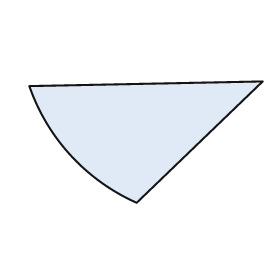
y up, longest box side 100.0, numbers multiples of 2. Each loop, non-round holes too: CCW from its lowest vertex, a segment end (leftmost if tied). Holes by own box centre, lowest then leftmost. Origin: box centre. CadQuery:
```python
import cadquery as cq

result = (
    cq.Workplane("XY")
    .moveTo(-4.0, -26.0)
    .lineTo(50.0, 26.0)
    .lineTo(-50.0, 24.0)
    .threePointArc((-32.0, -6.0), (-4.0, -26.0))
    .close()
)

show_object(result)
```